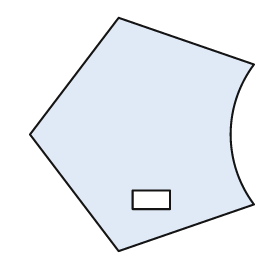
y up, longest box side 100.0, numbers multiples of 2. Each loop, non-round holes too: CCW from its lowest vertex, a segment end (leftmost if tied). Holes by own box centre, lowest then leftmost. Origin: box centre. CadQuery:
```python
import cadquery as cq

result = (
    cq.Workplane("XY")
    .moveTo(-10.0, -50.0)
    .lineTo(48.0, -30.0)
    .threePointArc((38.0, 0.0), (48.0, 30.0))
    .lineTo(-10.0, 50.0)
    .lineTo(-48.0, 0.0)
    .close()
    .moveTo(-4.0, -32.0)
    .lineTo(12.0, -32.0)
    .lineTo(12.0, -24.0)
    .lineTo(-4.0, -24.0)
    .close()
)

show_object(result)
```